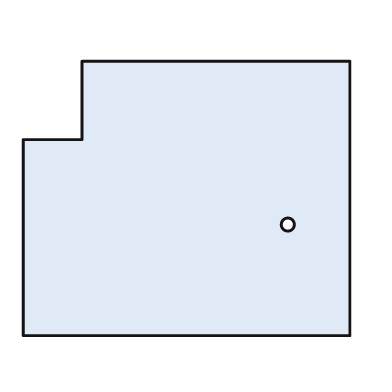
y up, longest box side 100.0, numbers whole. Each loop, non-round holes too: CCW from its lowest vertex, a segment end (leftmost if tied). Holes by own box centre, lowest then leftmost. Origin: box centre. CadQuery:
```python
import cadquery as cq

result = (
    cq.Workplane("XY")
    .moveTo(-50.0, -42.0)
    .lineTo(50.0, -42.0)
    .lineTo(50.0, 42.0)
    .lineTo(-32.0, 42.0)
    .lineTo(-32.0, 18.0)
    .lineTo(-50.0, 18.0)
    .close()
    .moveTo(31.0, -8.0)
    .circle(2.0)
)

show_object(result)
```